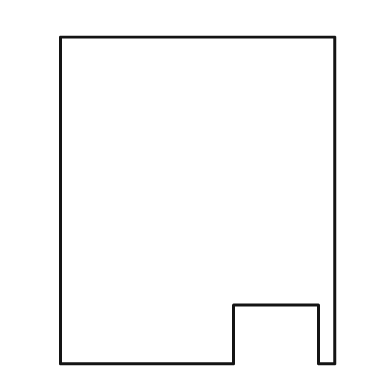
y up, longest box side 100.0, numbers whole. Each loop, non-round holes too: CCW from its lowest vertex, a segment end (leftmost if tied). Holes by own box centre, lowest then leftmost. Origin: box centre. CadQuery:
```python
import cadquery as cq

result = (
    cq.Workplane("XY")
    .moveTo(-42.0, -50.0)
    .lineTo(11.0, -50.0)
    .lineTo(11.0, -32.0)
    .lineTo(37.0, -32.0)
    .lineTo(37.0, -50.0)
    .lineTo(42.0, -50.0)
    .lineTo(42.0, 50.0)
    .lineTo(-42.0, 50.0)
    .close()
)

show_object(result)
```